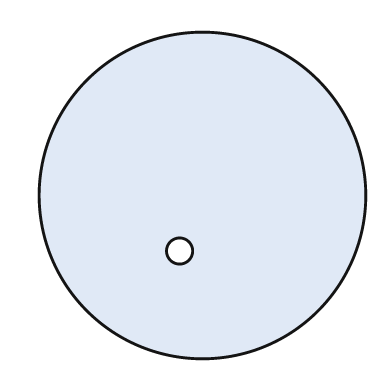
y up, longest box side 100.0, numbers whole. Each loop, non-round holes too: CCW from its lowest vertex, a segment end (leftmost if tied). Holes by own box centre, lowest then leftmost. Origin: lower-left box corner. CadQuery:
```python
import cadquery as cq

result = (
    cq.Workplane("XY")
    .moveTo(50.0, 50.0)
    .circle(50.0)
    .moveTo(43.0, 33.0)
    .circle(4.0)
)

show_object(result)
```